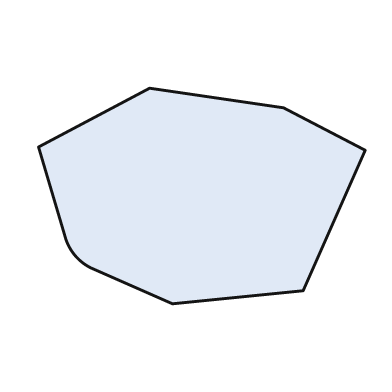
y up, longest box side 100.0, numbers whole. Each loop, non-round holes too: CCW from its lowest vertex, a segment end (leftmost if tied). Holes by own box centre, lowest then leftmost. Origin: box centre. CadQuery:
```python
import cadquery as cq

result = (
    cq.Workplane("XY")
    .moveTo(-9.0, -33.0)
    .lineTo(31.0, -29.0)
    .lineTo(50.0, 14.0)
    .lineTo(25.0, 27.0)
    .lineTo(-16.0, 33.0)
    .lineTo(-50.0, 15.0)
    .lineTo(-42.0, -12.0)
    .threePointArc((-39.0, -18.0), (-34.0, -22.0))
    .close()
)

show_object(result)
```